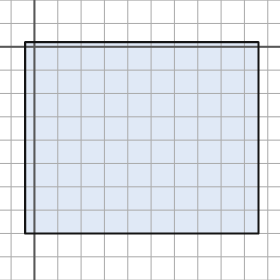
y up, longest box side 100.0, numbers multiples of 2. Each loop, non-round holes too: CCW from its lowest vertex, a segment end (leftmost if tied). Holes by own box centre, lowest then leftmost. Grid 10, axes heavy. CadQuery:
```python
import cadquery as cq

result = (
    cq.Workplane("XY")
    .moveTo(-4.0, -80.0)
    .lineTo(96.0, -80.0)
    .lineTo(96.0, 2.0)
    .lineTo(-4.0, 2.0)
    .close()
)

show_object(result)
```